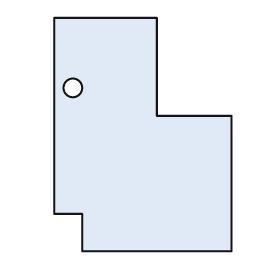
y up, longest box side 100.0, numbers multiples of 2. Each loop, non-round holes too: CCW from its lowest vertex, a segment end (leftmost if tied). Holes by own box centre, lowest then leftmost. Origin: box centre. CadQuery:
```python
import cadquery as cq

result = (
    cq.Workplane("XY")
    .moveTo(-26.0, -50.0)
    .lineTo(38.0, -50.0)
    .lineTo(38.0, 8.0)
    .lineTo(6.0, 8.0)
    .lineTo(6.0, 50.0)
    .lineTo(-38.0, 50.0)
    .lineTo(-38.0, -34.0)
    .lineTo(-26.0, -34.0)
    .close()
    .moveTo(-30.0, 20.0)
    .circle(4.0)
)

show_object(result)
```